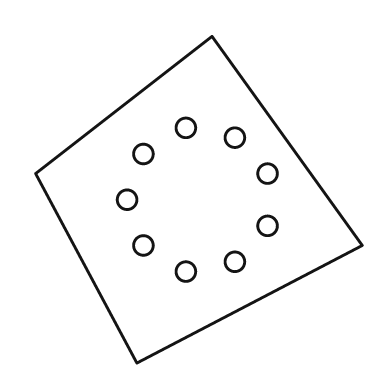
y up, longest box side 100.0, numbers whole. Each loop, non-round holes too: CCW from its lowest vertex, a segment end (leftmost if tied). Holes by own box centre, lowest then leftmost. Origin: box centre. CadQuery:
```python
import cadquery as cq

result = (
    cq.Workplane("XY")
    .moveTo(-19.0, -50.0)
    .lineTo(50.0, -14.0)
    .lineTo(4.0, 50.0)
    .lineTo(-50.0, 8.0)
    .close()
    .moveTo(-4.0, -22.0)
    .circle(3.0)
    .moveTo(11.0, -19.0)
    .circle(3.0)
    .moveTo(-17.0, -14.0)
    .circle(3.0)
    .moveTo(21.0, -8.0)
    .circle(3.0)
    .moveTo(-22.0, 0.0)
    .circle(3.0)
    .moveTo(21.0, 8.0)
    .circle(3.0)
    .moveTo(-17.0, 14.0)
    .circle(3.0)
    .moveTo(11.0, 19.0)
    .circle(3.0)
    .moveTo(-4.0, 22.0)
    .circle(3.0)
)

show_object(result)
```